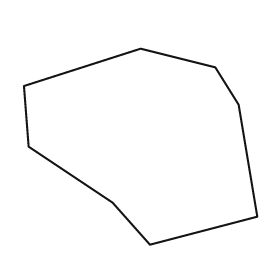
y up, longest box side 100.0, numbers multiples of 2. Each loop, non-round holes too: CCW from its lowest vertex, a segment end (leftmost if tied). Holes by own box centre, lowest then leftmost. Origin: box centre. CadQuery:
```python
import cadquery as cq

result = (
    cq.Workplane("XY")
    .moveTo(4.0, -42.0)
    .lineTo(50.0, -30.0)
    .lineTo(42.0, 18.0)
    .lineTo(32.0, 34.0)
    .lineTo(0.0, 42.0)
    .lineTo(-50.0, 26.0)
    .lineTo(-48.0, 0.0)
    .lineTo(-12.0, -24.0)
    .close()
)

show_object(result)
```